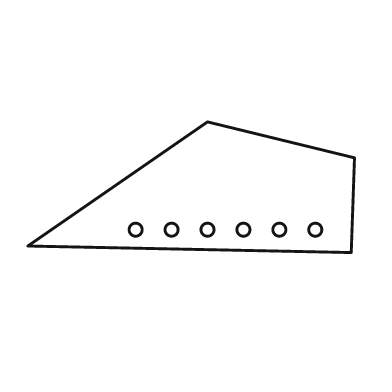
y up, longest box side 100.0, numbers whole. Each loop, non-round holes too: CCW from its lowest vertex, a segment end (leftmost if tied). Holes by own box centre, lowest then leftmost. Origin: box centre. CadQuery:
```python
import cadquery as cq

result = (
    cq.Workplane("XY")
    .moveTo(49.0, -20.0)
    .lineTo(50.0, 9.0)
    .lineTo(5.0, 20.0)
    .lineTo(-50.0, -18.0)
    .close()
    .moveTo(-17.0, -13.0)
    .circle(2.0)
    .moveTo(-6.0, -13.0)
    .circle(2.0)
    .moveTo(5.0, -13.0)
    .circle(2.0)
    .moveTo(16.0, -13.0)
    .circle(2.0)
    .moveTo(27.0, -13.0)
    .circle(2.0)
    .moveTo(38.0, -13.0)
    .circle(2.0)
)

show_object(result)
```